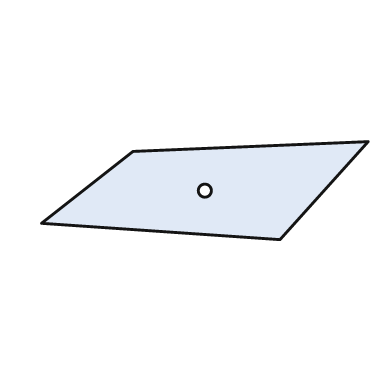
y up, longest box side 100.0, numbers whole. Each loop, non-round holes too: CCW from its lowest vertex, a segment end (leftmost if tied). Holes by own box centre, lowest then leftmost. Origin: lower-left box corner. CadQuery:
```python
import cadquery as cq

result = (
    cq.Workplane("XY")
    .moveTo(73.0, 0.0)
    .lineTo(100.0, 30.0)
    .lineTo(28.0, 27.0)
    .lineTo(0.0, 5.0)
    .close()
    .moveTo(50.0, 15.0)
    .circle(2.0)
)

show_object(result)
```